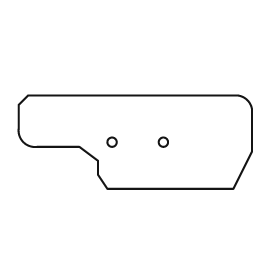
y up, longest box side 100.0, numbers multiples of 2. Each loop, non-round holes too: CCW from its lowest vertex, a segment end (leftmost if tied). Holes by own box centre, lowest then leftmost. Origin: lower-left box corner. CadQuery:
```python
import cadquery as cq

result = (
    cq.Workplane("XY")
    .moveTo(38.0, 0.0)
    .lineTo(92.0, 0.0)
    .lineTo(100.0, 16.0)
    .lineTo(100.0, 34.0)
    .threePointArc((98.0, 38.0), (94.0, 40.0))
    .lineTo(4.0, 40.0)
    .lineTo(0.0, 36.0)
    .lineTo(0.0, 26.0)
    .threePointArc((2.0, 20.0), (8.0, 18.0))
    .lineTo(26.0, 18.0)
    .lineTo(34.0, 12.0)
    .lineTo(34.0, 6.0)
    .close()
    .moveTo(40.0, 20.0)
    .circle(2.0)
    .moveTo(62.0, 20.0)
    .circle(2.0)
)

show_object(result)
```